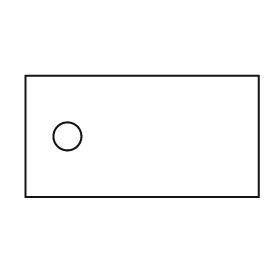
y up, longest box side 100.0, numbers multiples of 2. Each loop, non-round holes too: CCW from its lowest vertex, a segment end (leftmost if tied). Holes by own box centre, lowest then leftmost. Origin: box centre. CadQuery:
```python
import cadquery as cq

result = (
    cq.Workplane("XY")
    .moveTo(-50.0, -26.0)
    .lineTo(50.0, -26.0)
    .lineTo(50.0, 26.0)
    .lineTo(-50.0, 26.0)
    .close()
    .moveTo(-32.0, 0.0)
    .circle(6.0)
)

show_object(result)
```